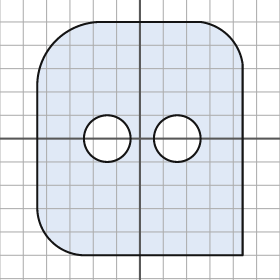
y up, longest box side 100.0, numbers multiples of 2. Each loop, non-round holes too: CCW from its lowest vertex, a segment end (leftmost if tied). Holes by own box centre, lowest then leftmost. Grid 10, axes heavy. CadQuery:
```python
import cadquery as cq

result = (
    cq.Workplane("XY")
    .moveTo(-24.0, -50.0)
    .lineTo(44.0, -50.0)
    .lineTo(44.0, 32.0)
    .threePointArc((38.0, 44.0), (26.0, 50.0))
    .lineTo(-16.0, 50.0)
    .threePointArc((-36.0, 42.0), (-44.0, 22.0))
    .lineTo(-44.0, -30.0)
    .threePointArc((-38.0, -44.0), (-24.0, -50.0))
    .close()
    .moveTo(-14.0, 0.0)
    .circle(10.0)
    .moveTo(16.0, 0.0)
    .circle(10.0)
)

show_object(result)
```